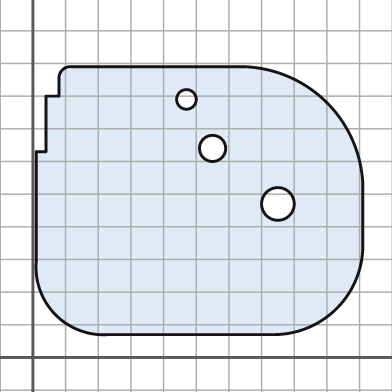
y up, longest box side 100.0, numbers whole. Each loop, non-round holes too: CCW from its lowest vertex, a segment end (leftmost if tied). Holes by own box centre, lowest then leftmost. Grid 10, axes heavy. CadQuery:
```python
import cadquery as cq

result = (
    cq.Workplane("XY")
    .moveTo(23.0, 7.0)
    .lineTo(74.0, 7.0)
    .threePointArc((93.0, 15.0), (101.0, 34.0))
    .lineTo(101.0, 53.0)
    .threePointArc((90.0, 78.0), (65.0, 89.0))
    .lineTo(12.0, 89.0)
    .threePointArc((9.0, 88.0), (8.0, 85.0))
    .lineTo(8.0, 80.0)
    .lineTo(4.0, 80.0)
    .lineTo(4.0, 63.0)
    .lineTo(1.0, 63.0)
    .lineTo(1.0, 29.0)
    .threePointArc((7.0, 13.0), (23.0, 7.0))
    .close()
    .moveTo(75.0, 47.0)
    .circle(5.0)
    .moveTo(55.0, 64.0)
    .circle(4.0)
    .moveTo(47.0, 79.0)
    .circle(3.0)
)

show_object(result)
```